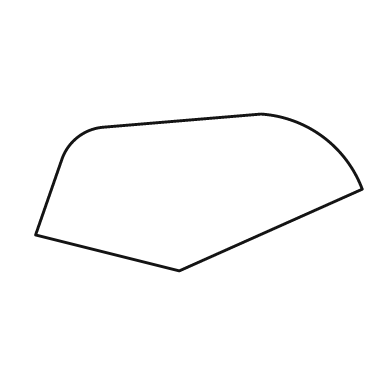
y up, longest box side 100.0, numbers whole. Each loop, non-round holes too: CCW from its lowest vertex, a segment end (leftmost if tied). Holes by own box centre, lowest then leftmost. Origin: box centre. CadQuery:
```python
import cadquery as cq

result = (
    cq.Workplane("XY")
    .moveTo(-6.0, -24.0)
    .lineTo(50.0, 1.0)
    .threePointArc((38.0, 17.0), (19.0, 24.0))
    .lineTo(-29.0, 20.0)
    .threePointArc((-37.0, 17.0), (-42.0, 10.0))
    .lineTo(-50.0, -13.0)
    .close()
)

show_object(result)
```